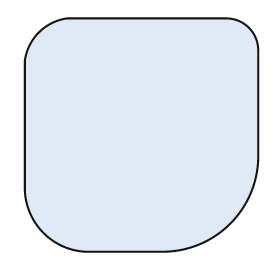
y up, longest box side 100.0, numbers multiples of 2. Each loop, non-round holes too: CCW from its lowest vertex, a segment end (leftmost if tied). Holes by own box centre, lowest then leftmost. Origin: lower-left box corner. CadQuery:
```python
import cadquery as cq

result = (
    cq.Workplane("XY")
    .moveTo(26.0, 0.0)
    .lineTo(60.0, 0.0)
    .threePointArc((88.0, 12.0), (100.0, 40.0))
    .lineTo(100.0, 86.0)
    .threePointArc((96.0, 96.0), (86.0, 100.0))
    .lineTo(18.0, 100.0)
    .threePointArc((6.0, 94.0), (0.0, 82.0))
    .lineTo(0.0, 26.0)
    .threePointArc((8.0, 8.0), (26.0, 0.0))
    .close()
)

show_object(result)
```